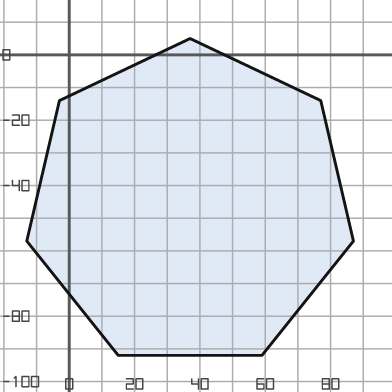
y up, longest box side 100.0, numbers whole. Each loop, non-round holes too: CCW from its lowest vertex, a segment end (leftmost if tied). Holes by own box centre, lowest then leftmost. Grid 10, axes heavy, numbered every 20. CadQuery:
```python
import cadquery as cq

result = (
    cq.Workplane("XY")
    .moveTo(15.0, -92.0)
    .lineTo(59.0, -92.0)
    .lineTo(87.0, -57.0)
    .lineTo(77.0, -14.0)
    .lineTo(37.0, 5.0)
    .lineTo(-3.0, -14.0)
    .lineTo(-13.0, -57.0)
    .close()
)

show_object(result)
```